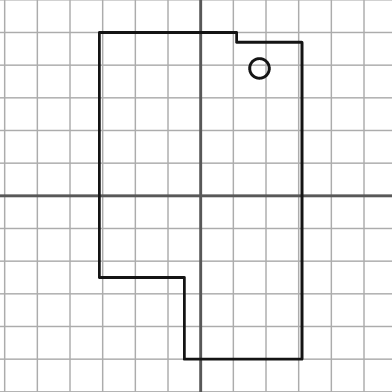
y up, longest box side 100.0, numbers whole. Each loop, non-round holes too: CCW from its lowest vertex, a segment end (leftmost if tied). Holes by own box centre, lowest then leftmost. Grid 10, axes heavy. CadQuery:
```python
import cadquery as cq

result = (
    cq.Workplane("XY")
    .moveTo(-5.0, -50.0)
    .lineTo(31.0, -50.0)
    .lineTo(31.0, 47.0)
    .lineTo(11.0, 47.0)
    .lineTo(11.0, 50.0)
    .lineTo(-31.0, 50.0)
    .lineTo(-31.0, -25.0)
    .lineTo(-5.0, -25.0)
    .close()
    .moveTo(18.0, 39.0)
    .circle(3.0)
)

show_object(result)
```